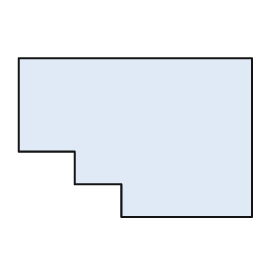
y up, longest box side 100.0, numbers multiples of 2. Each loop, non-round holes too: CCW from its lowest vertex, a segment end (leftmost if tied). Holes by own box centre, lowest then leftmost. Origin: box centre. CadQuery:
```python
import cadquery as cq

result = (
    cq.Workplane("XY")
    .moveTo(-6.0, -34.0)
    .lineTo(50.0, -34.0)
    .lineTo(50.0, 34.0)
    .lineTo(-50.0, 34.0)
    .lineTo(-50.0, -6.0)
    .lineTo(-26.0, -6.0)
    .lineTo(-26.0, -20.0)
    .lineTo(-6.0, -20.0)
    .close()
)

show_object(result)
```